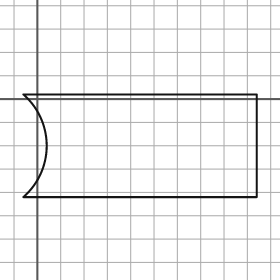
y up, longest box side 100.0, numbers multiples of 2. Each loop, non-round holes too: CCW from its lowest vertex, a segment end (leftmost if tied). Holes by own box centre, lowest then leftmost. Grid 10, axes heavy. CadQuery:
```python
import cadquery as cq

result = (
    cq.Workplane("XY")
    .moveTo(-6.0, -42.0)
    .lineTo(94.0, -42.0)
    .lineTo(94.0, 2.0)
    .lineTo(-6.0, 2.0)
    .threePointArc((4.0, -20.0), (-6.0, -42.0))
    .close()
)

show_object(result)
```